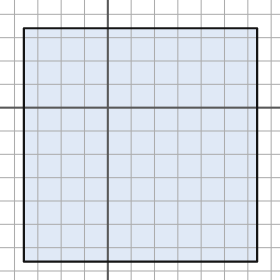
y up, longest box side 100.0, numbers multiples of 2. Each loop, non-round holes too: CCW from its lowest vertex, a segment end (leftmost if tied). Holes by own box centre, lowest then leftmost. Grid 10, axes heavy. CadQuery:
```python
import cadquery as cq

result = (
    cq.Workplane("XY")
    .moveTo(-36.0, -66.0)
    .lineTo(64.0, -66.0)
    .lineTo(64.0, 34.0)
    .lineTo(-36.0, 34.0)
    .close()
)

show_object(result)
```